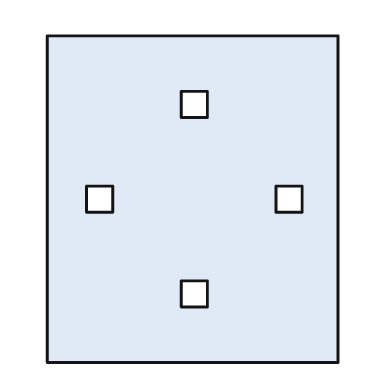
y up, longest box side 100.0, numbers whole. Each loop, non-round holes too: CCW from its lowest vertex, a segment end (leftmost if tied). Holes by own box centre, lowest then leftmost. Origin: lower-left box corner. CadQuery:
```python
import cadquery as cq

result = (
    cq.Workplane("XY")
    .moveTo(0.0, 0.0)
    .lineTo(89.0, 0.0)
    .lineTo(89.0, 100.0)
    .lineTo(0.0, 100.0)
    .close()
    .moveTo(41.0, 17.0)
    .lineTo(49.0, 17.0)
    .lineTo(49.0, 25.0)
    .lineTo(41.0, 25.0)
    .close()
    .moveTo(12.0, 46.0)
    .lineTo(20.0, 46.0)
    .lineTo(20.0, 54.0)
    .lineTo(12.0, 54.0)
    .close()
    .moveTo(70.0, 46.0)
    .lineTo(78.0, 46.0)
    .lineTo(78.0, 54.0)
    .lineTo(70.0, 54.0)
    .close()
    .moveTo(41.0, 75.0)
    .lineTo(49.0, 75.0)
    .lineTo(49.0, 83.0)
    .lineTo(41.0, 83.0)
    .close()
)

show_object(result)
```